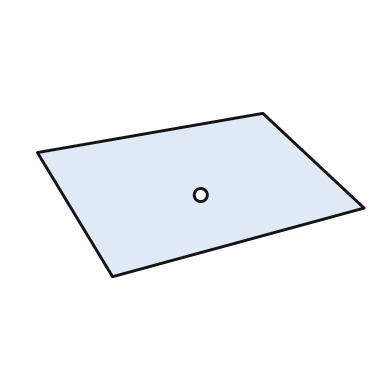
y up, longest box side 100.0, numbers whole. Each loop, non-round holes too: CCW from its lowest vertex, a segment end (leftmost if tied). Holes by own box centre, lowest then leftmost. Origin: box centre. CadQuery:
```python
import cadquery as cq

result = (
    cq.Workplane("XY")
    .moveTo(-27.0, -25.0)
    .lineTo(50.0, -4.0)
    .lineTo(19.0, 25.0)
    .lineTo(-50.0, 13.0)
    .close()
    .moveTo(0.0, 0.0)
    .circle(2.0)
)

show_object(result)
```